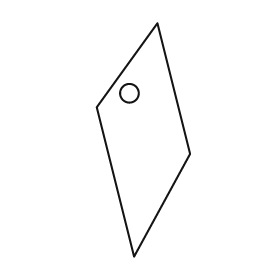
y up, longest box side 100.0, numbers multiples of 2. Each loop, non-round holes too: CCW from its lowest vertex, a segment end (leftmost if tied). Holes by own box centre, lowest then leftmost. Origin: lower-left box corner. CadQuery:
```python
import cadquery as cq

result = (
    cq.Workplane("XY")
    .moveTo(16.0, 0.0)
    .lineTo(40.0, 44.0)
    .lineTo(26.0, 100.0)
    .lineTo(0.0, 64.0)
    .close()
    .moveTo(14.0, 70.0)
    .circle(4.0)
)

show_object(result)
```